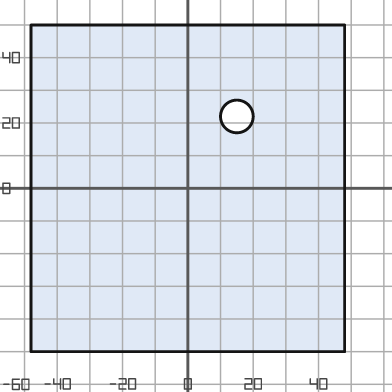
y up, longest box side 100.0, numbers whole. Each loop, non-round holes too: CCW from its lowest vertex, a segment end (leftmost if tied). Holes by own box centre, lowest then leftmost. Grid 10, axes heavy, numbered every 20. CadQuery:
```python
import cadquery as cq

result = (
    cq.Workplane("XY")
    .moveTo(-48.0, -50.0)
    .lineTo(48.0, -50.0)
    .lineTo(48.0, 50.0)
    .lineTo(-48.0, 50.0)
    .close()
    .moveTo(15.0, 22.0)
    .circle(5.0)
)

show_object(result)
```